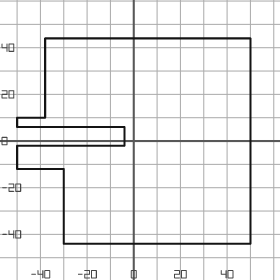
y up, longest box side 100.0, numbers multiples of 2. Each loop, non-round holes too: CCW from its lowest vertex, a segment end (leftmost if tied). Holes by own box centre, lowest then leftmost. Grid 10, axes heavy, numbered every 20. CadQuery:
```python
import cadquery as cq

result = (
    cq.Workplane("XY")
    .moveTo(-30.0, -44.0)
    .lineTo(50.0, -44.0)
    .lineTo(50.0, 44.0)
    .lineTo(-38.0, 44.0)
    .lineTo(-38.0, 10.0)
    .lineTo(-50.0, 10.0)
    .lineTo(-50.0, 6.0)
    .lineTo(-4.0, 6.0)
    .lineTo(-4.0, -2.0)
    .lineTo(-50.0, -2.0)
    .lineTo(-50.0, -12.0)
    .lineTo(-30.0, -12.0)
    .close()
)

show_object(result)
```